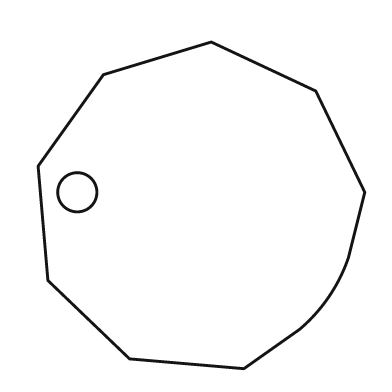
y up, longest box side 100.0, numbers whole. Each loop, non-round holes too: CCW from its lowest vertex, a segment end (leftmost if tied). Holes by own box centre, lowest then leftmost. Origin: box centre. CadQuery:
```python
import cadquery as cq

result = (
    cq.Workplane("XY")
    .moveTo(13.0, -50.0)
    .lineTo(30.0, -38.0)
    .threePointArc((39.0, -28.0), (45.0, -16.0))
    .lineTo(50.0, 4.0)
    .lineTo(35.0, 35.0)
    .lineTo(3.0, 50.0)
    .lineTo(-30.0, 40.0)
    .lineTo(-50.0, 12.0)
    .lineTo(-47.0, -23.0)
    .lineTo(-22.0, -47.0)
    .close()
    .moveTo(-38.0, 4.0)
    .circle(6.0)
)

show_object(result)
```